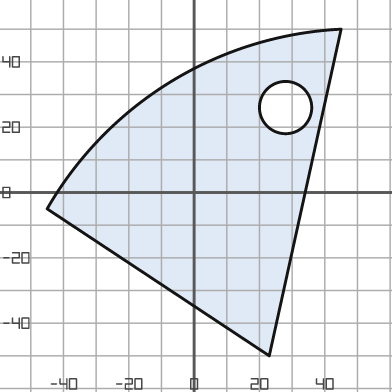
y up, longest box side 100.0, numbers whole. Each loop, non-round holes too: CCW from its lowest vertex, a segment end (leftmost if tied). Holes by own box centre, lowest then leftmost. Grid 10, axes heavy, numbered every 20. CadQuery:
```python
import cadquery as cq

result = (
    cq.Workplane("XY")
    .moveTo(23.0, -50.0)
    .lineTo(45.0, 50.0)
    .threePointArc((-7.0, 34.0), (-45.0, -5.0))
    .close()
    .moveTo(28.0, 26.0)
    .circle(8.0)
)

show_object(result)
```